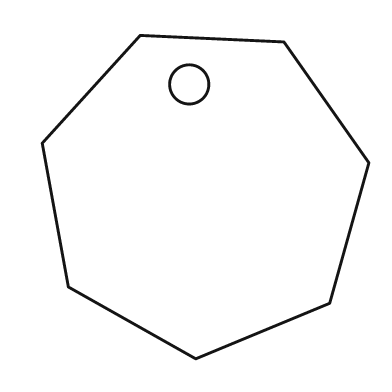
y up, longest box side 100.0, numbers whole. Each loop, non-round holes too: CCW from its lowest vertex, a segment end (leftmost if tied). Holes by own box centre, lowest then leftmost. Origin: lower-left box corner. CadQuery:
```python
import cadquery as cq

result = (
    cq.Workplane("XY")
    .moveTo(47.0, 0.0)
    .lineTo(88.0, 17.0)
    .lineTo(100.0, 60.0)
    .lineTo(74.0, 97.0)
    .lineTo(30.0, 99.0)
    .lineTo(0.0, 66.0)
    .lineTo(8.0, 22.0)
    .close()
    .moveTo(45.0, 84.0)
    .circle(6.0)
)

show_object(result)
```